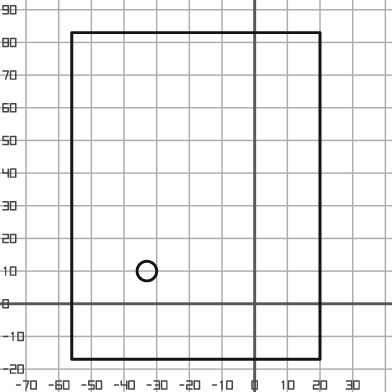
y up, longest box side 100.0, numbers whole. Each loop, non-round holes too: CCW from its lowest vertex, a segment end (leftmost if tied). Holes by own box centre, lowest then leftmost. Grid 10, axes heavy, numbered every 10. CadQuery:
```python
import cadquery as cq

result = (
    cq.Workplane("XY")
    .moveTo(-56.0, -17.0)
    .lineTo(20.0, -17.0)
    .lineTo(20.0, 83.0)
    .lineTo(-56.0, 83.0)
    .close()
    .moveTo(-33.0, 10.0)
    .circle(3.0)
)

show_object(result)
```